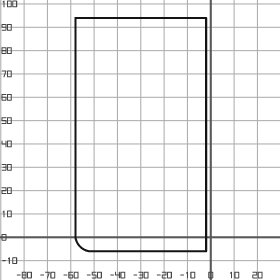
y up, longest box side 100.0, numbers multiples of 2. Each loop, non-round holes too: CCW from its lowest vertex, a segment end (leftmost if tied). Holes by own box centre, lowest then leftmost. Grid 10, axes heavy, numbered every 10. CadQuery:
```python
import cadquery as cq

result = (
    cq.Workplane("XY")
    .moveTo(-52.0, -6.0)
    .lineTo(-2.0, -6.0)
    .lineTo(-2.0, 94.0)
    .lineTo(-58.0, 94.0)
    .lineTo(-58.0, 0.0)
    .threePointArc((-56.0, -4.0), (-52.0, -6.0))
    .close()
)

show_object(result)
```